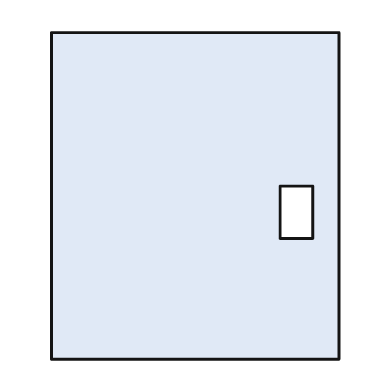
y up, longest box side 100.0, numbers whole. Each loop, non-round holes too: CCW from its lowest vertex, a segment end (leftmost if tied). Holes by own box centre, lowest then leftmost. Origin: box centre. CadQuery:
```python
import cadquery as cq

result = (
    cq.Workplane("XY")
    .moveTo(-44.0, -50.0)
    .lineTo(44.0, -50.0)
    .lineTo(44.0, 50.0)
    .lineTo(-44.0, 50.0)
    .close()
    .moveTo(26.0, -13.0)
    .lineTo(36.0, -13.0)
    .lineTo(36.0, 3.0)
    .lineTo(26.0, 3.0)
    .close()
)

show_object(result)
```